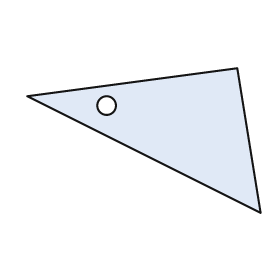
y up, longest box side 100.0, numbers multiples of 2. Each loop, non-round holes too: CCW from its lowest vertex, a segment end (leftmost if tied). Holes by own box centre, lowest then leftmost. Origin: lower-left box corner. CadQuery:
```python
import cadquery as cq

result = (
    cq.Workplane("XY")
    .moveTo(100.0, 0.0)
    .lineTo(90.0, 62.0)
    .lineTo(0.0, 50.0)
    .close()
    .moveTo(34.0, 46.0)
    .circle(4.0)
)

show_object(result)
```